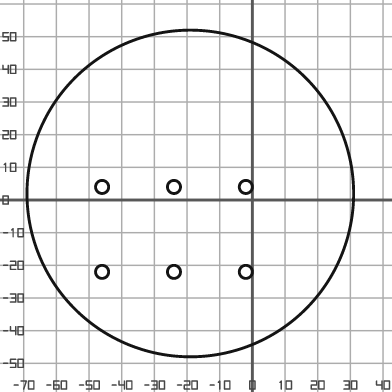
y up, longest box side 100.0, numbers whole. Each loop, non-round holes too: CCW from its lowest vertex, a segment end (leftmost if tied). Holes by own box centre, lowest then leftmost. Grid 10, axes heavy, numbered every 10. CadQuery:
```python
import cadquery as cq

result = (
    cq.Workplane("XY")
    .moveTo(-19.0, 2.0)
    .circle(50.0)
    .moveTo(-46.0, -22.0)
    .circle(2.0)
    .moveTo(-24.0, -22.0)
    .circle(2.0)
    .moveTo(-2.0, -22.0)
    .circle(2.0)
    .moveTo(-46.0, 4.0)
    .circle(2.0)
    .moveTo(-24.0, 4.0)
    .circle(2.0)
    .moveTo(-2.0, 4.0)
    .circle(2.0)
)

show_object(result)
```